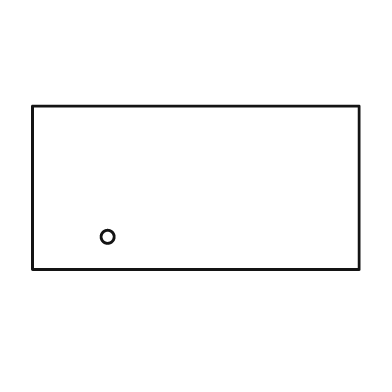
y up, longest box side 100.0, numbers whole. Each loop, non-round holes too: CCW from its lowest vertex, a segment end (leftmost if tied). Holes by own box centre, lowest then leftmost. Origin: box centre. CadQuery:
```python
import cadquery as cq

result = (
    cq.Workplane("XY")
    .moveTo(-50.0, -25.0)
    .lineTo(50.0, -25.0)
    .lineTo(50.0, 25.0)
    .lineTo(-50.0, 25.0)
    .close()
    .moveTo(-27.0, -15.0)
    .circle(2.0)
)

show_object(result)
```